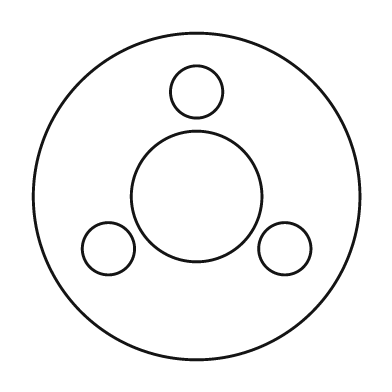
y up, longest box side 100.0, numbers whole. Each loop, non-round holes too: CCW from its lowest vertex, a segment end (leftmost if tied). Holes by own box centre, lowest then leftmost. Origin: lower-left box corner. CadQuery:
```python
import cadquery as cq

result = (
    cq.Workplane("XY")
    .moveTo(50.0, 50.0)
    .circle(50.0)
    .moveTo(23.0, 34.0)
    .circle(8.0)
    .moveTo(77.0, 34.0)
    .circle(8.0)
    .moveTo(50.0, 50.0)
    .circle(20.0)
    .moveTo(50.0, 82.0)
    .circle(8.0)
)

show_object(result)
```